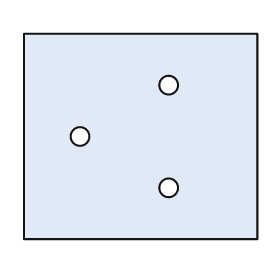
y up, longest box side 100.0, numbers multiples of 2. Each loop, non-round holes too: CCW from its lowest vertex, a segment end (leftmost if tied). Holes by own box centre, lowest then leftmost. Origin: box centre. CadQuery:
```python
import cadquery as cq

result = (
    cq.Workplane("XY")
    .moveTo(-50.0, -44.0)
    .lineTo(50.0, -44.0)
    .lineTo(50.0, 44.0)
    .lineTo(-50.0, 44.0)
    .close()
    .moveTo(12.0, -22.0)
    .circle(4.0)
    .moveTo(-26.0, 0.0)
    .circle(4.0)
    .moveTo(12.0, 22.0)
    .circle(4.0)
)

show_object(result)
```